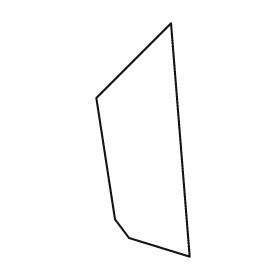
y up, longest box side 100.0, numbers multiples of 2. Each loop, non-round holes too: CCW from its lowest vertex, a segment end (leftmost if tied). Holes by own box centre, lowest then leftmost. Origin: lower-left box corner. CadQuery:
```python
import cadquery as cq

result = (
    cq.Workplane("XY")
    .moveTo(40.0, 0.0)
    .lineTo(32.0, 100.0)
    .lineTo(0.0, 68.0)
    .lineTo(8.0, 16.0)
    .lineTo(14.0, 8.0)
    .close()
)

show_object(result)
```